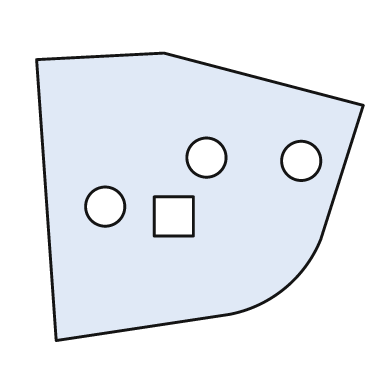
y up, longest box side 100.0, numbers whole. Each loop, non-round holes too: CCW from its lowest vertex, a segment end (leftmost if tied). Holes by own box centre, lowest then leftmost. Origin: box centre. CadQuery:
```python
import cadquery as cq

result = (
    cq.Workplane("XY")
    .moveTo(-44.0, -44.0)
    .lineTo(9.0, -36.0)
    .threePointArc((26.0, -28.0), (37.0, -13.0))
    .lineTo(50.0, 28.0)
    .lineTo(-11.0, 44.0)
    .lineTo(-50.0, 42.0)
    .close()
    .moveTo(-14.0, -12.0)
    .lineTo(-2.0, -12.0)
    .lineTo(-2.0, 0.0)
    .lineTo(-14.0, 0.0)
    .close()
    .moveTo(-29.0, -3.0)
    .circle(6.0)
    .moveTo(31.0, 11.0)
    .circle(6.0)
    .moveTo(2.0, 12.0)
    .circle(6.0)
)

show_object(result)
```